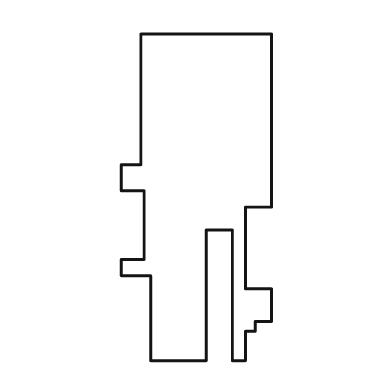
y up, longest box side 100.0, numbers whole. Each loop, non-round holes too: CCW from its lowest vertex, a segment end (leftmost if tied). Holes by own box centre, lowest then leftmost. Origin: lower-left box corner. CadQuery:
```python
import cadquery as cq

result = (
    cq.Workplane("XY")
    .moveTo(9.0, 0.0)
    .lineTo(26.0, 0.0)
    .lineTo(26.0, 40.0)
    .lineTo(34.0, 40.0)
    .lineTo(34.0, 0.0)
    .lineTo(38.0, 0.0)
    .lineTo(38.0, 9.0)
    .lineTo(41.0, 9.0)
    .lineTo(41.0, 12.0)
    .lineTo(46.0, 12.0)
    .lineTo(46.0, 22.0)
    .lineTo(38.0, 22.0)
    .lineTo(38.0, 47.0)
    .lineTo(46.0, 47.0)
    .lineTo(46.0, 100.0)
    .lineTo(6.0, 100.0)
    .lineTo(6.0, 60.0)
    .lineTo(0.0, 60.0)
    .lineTo(0.0, 52.0)
    .lineTo(7.0, 52.0)
    .lineTo(7.0, 31.0)
    .lineTo(0.0, 31.0)
    .lineTo(0.0, 26.0)
    .lineTo(9.0, 26.0)
    .close()
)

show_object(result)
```